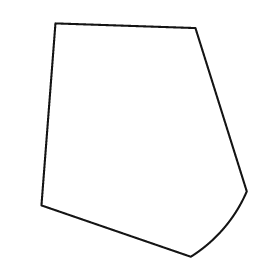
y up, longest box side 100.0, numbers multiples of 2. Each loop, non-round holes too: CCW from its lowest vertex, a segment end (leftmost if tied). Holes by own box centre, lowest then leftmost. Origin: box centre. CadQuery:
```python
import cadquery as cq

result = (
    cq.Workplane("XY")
    .moveTo(20.0, -50.0)
    .threePointArc((34.0, -38.0), (44.0, -22.0))
    .lineTo(22.0, 48.0)
    .lineTo(-38.0, 50.0)
    .lineTo(-44.0, -28.0)
    .close()
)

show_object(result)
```